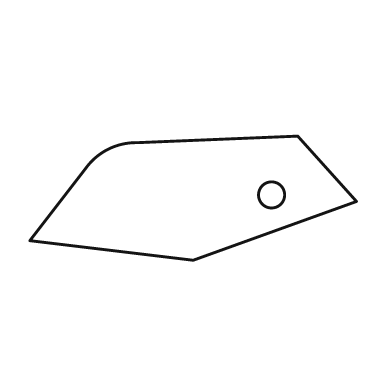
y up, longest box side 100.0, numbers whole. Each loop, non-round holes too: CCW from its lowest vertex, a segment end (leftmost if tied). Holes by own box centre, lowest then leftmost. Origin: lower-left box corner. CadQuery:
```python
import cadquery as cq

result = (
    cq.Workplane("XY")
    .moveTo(50.0, 0.0)
    .lineTo(100.0, 18.0)
    .lineTo(82.0, 38.0)
    .lineTo(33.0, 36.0)
    .threePointArc((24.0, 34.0), (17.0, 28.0))
    .lineTo(0.0, 6.0)
    .close()
    .moveTo(74.0, 20.0)
    .circle(4.0)
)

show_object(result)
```